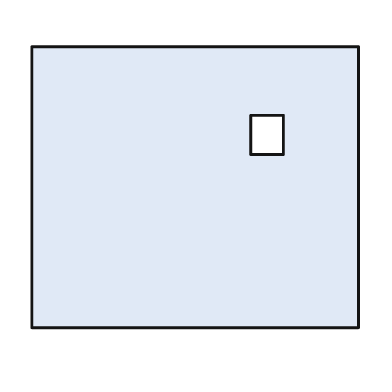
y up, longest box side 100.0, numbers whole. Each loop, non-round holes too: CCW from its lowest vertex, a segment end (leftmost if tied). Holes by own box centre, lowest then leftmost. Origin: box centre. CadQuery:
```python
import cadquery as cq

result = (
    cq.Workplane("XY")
    .moveTo(-50.0, -43.0)
    .lineTo(50.0, -43.0)
    .lineTo(50.0, 43.0)
    .lineTo(-50.0, 43.0)
    .close()
    .moveTo(17.0, 10.0)
    .lineTo(27.0, 10.0)
    .lineTo(27.0, 22.0)
    .lineTo(17.0, 22.0)
    .close()
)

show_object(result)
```